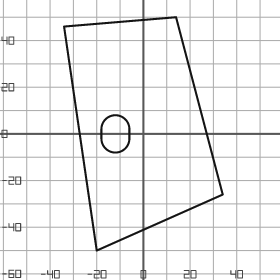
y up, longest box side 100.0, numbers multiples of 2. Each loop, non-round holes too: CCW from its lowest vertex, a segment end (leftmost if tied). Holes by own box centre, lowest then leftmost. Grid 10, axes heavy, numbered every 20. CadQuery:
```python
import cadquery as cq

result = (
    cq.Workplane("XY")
    .moveTo(-20.0, -50.0)
    .lineTo(34.0, -26.0)
    .lineTo(14.0, 50.0)
    .lineTo(-34.0, 46.0)
    .close()
    .moveTo(-18.0, -2.0)
    .threePointArc((-12.0, -8.0), (-6.0, -2.0))
    .lineTo(-6.0, 2.0)
    .threePointArc((-12.0, 8.0), (-18.0, 2.0))
    .close()
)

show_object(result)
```